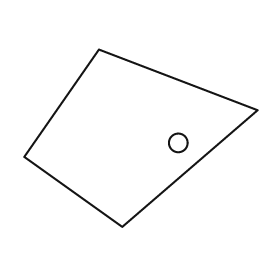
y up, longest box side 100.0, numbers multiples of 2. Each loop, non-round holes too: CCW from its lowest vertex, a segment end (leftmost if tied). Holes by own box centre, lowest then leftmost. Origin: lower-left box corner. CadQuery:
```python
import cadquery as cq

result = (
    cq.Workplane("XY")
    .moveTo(42.0, 0.0)
    .lineTo(100.0, 50.0)
    .lineTo(32.0, 76.0)
    .lineTo(0.0, 30.0)
    .close()
    .moveTo(66.0, 36.0)
    .circle(4.0)
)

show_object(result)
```